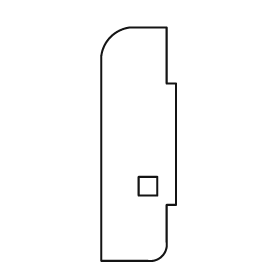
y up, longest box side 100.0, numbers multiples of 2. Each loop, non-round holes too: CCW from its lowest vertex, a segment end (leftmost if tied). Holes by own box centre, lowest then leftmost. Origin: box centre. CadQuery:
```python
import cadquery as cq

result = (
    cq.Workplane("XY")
    .moveTo(-16.0, -50.0)
    .lineTo(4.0, -50.0)
    .threePointArc((10.0, -48.0), (12.0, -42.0))
    .lineTo(12.0, -26.0)
    .lineTo(16.0, -26.0)
    .lineTo(16.0, 26.0)
    .lineTo(12.0, 26.0)
    .lineTo(12.0, 50.0)
    .lineTo(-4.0, 50.0)
    .threePointArc((-12.0, 46.0), (-16.0, 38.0))
    .close()
    .moveTo(0.0, -22.0)
    .lineTo(8.0, -22.0)
    .lineTo(8.0, -14.0)
    .lineTo(0.0, -14.0)
    .close()
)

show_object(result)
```